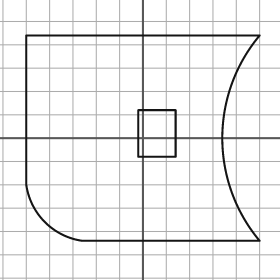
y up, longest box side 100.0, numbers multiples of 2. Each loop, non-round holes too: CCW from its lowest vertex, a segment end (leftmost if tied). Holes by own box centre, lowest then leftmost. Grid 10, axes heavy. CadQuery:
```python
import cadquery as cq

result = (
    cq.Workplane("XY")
    .moveTo(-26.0, -44.0)
    .lineTo(50.0, -44.0)
    .threePointArc((34.0, 0.0), (50.0, 44.0))
    .lineTo(-50.0, 44.0)
    .lineTo(-50.0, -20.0)
    .threePointArc((-42.0, -36.0), (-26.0, -44.0))
    .close()
    .moveTo(-2.0, -8.0)
    .lineTo(14.0, -8.0)
    .lineTo(14.0, 12.0)
    .lineTo(-2.0, 12.0)
    .close()
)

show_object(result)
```